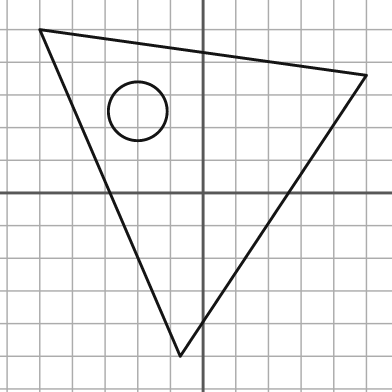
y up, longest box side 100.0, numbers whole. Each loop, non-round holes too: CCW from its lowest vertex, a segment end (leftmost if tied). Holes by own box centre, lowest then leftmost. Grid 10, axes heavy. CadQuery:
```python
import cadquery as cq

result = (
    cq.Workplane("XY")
    .moveTo(-7.0, -50.0)
    .lineTo(50.0, 36.0)
    .lineTo(-50.0, 50.0)
    .close()
    .moveTo(-20.0, 25.0)
    .circle(9.0)
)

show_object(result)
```